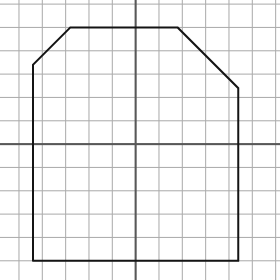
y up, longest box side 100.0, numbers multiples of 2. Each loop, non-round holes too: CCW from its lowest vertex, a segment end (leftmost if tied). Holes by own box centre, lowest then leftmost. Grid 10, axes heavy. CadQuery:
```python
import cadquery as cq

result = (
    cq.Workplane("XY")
    .moveTo(-44.0, -50.0)
    .lineTo(44.0, -50.0)
    .lineTo(44.0, 24.0)
    .lineTo(18.0, 50.0)
    .lineTo(-28.0, 50.0)
    .lineTo(-44.0, 34.0)
    .close()
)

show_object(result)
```